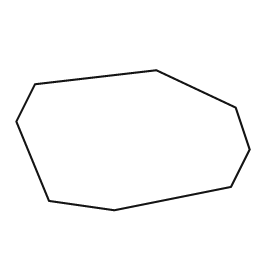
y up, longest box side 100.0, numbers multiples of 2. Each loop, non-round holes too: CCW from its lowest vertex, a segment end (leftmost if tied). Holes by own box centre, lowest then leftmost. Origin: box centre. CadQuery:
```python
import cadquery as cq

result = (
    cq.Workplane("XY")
    .moveTo(-8.0, -30.0)
    .lineTo(42.0, -20.0)
    .lineTo(50.0, -4.0)
    .lineTo(44.0, 14.0)
    .lineTo(10.0, 30.0)
    .lineTo(-42.0, 24.0)
    .lineTo(-50.0, 8.0)
    .lineTo(-36.0, -26.0)
    .close()
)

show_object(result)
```